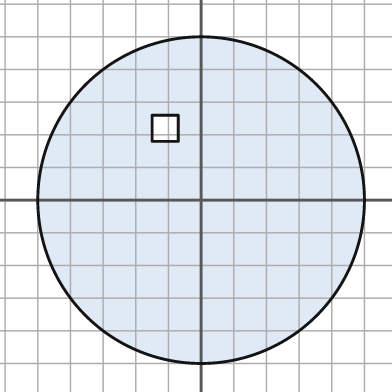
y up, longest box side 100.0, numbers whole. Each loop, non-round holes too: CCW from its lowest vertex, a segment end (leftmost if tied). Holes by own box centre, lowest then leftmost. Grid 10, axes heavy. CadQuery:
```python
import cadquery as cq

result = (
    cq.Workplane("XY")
    .moveTo(0.0, 0.0)
    .circle(50.0)
    .moveTo(-15.0, 18.0)
    .lineTo(-7.0, 18.0)
    .lineTo(-7.0, 26.0)
    .lineTo(-15.0, 26.0)
    .close()
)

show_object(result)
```